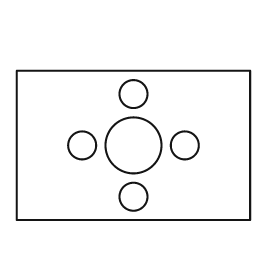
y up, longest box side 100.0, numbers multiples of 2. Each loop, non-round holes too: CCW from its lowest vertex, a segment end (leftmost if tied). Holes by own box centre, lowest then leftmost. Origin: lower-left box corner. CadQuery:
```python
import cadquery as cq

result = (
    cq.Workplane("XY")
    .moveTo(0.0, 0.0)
    .lineTo(100.0, 0.0)
    .lineTo(100.0, 64.0)
    .lineTo(0.0, 64.0)
    .close()
    .moveTo(50.0, 10.0)
    .circle(6.0)
    .moveTo(28.0, 32.0)
    .circle(6.0)
    .moveTo(50.0, 32.0)
    .circle(12.0)
    .moveTo(72.0, 32.0)
    .circle(6.0)
    .moveTo(50.0, 54.0)
    .circle(6.0)
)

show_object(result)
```